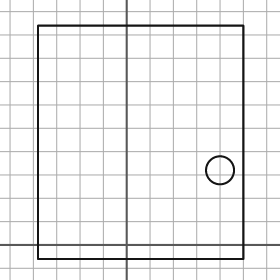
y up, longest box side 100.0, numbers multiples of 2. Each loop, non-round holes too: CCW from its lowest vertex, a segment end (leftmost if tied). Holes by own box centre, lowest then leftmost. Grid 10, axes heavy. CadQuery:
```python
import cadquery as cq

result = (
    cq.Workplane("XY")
    .moveTo(-38.0, -6.0)
    .lineTo(50.0, -6.0)
    .lineTo(50.0, 94.0)
    .lineTo(-38.0, 94.0)
    .close()
    .moveTo(40.0, 32.0)
    .circle(6.0)
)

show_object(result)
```